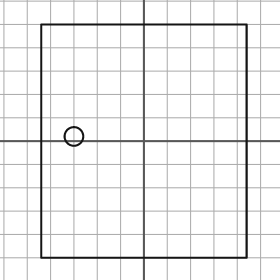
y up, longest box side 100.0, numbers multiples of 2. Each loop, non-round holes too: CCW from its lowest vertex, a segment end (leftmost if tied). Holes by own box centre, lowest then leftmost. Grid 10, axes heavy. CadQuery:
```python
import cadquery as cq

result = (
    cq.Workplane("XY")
    .moveTo(-44.0, -50.0)
    .lineTo(44.0, -50.0)
    .lineTo(44.0, 50.0)
    .lineTo(-44.0, 50.0)
    .close()
    .moveTo(-30.0, 2.0)
    .circle(4.0)
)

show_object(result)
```